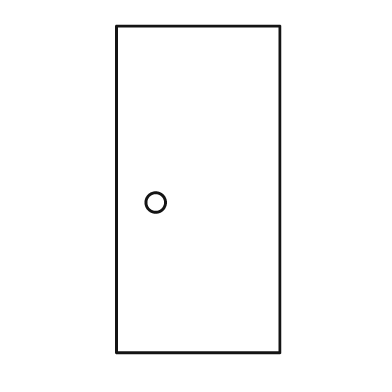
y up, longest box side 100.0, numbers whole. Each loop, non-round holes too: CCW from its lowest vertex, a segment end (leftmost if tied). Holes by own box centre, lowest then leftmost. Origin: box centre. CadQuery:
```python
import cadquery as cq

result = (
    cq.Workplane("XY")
    .moveTo(-25.0, -50.0)
    .lineTo(25.0, -50.0)
    .lineTo(25.0, 50.0)
    .lineTo(-25.0, 50.0)
    .close()
    .moveTo(-13.0, -4.0)
    .circle(3.0)
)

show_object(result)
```